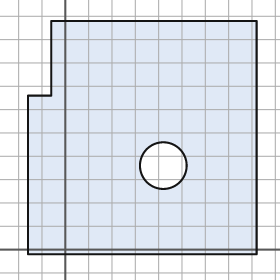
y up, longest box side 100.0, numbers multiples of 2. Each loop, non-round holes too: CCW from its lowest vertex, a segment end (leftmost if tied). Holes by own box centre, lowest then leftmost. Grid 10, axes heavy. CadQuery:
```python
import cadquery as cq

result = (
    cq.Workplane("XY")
    .moveTo(-16.0, -2.0)
    .lineTo(82.0, -2.0)
    .lineTo(82.0, 98.0)
    .lineTo(-6.0, 98.0)
    .lineTo(-6.0, 66.0)
    .lineTo(-16.0, 66.0)
    .close()
    .moveTo(42.0, 36.0)
    .circle(10.0)
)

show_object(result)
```